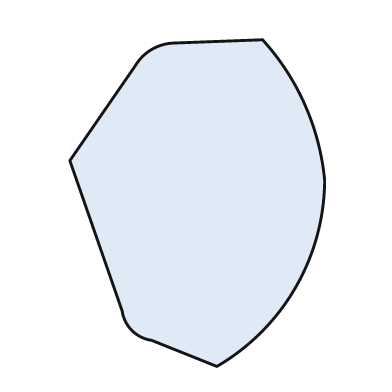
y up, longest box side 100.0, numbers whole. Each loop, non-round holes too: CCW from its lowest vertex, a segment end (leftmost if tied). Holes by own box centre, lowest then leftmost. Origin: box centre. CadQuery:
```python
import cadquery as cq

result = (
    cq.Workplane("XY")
    .moveTo(6.0, -50.0)
    .threePointArc((30.0, -26.0), (39.0, 7.0))
    .threePointArc((33.0, 30.0), (20.0, 50.0))
    .lineTo(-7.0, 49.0)
    .threePointArc((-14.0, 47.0), (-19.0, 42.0))
    .lineTo(-39.0, 13.0)
    .lineTo(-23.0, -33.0)
    .threePointArc((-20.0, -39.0), (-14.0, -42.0))
    .close()
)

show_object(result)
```